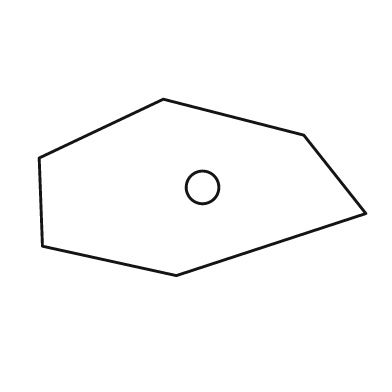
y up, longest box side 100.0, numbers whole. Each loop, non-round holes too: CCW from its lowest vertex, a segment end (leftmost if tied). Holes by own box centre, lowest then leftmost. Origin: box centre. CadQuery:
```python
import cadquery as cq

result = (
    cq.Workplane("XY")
    .moveTo(-8.0, -27.0)
    .lineTo(50.0, -8.0)
    .lineTo(31.0, 16.0)
    .lineTo(-12.0, 27.0)
    .lineTo(-50.0, 9.0)
    .lineTo(-49.0, -18.0)
    .close()
    .moveTo(0.0, 0.0)
    .circle(5.0)
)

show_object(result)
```